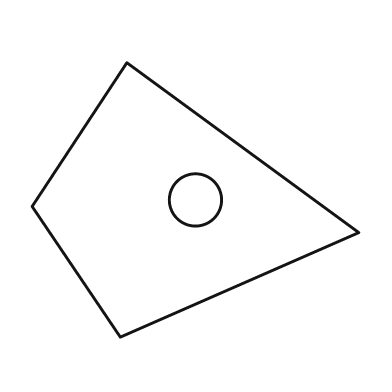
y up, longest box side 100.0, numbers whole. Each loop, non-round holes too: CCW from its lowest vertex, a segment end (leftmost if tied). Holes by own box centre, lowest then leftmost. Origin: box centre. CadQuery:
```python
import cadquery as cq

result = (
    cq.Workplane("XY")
    .moveTo(-23.0, -42.0)
    .lineTo(50.0, -10.0)
    .lineTo(-21.0, 42.0)
    .lineTo(-50.0, -2.0)
    .close()
    .moveTo(0.0, 0.0)
    .circle(8.0)
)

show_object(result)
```